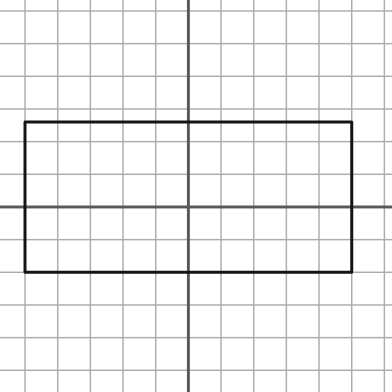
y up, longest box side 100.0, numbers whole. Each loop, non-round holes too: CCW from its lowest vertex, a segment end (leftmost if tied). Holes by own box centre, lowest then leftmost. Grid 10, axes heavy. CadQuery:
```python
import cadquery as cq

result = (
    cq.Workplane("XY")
    .moveTo(-50.0, -20.0)
    .lineTo(50.0, -20.0)
    .lineTo(50.0, 26.0)
    .lineTo(-50.0, 26.0)
    .close()
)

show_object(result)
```